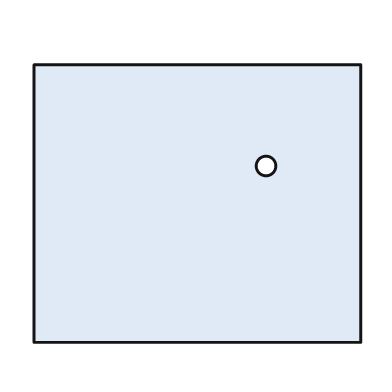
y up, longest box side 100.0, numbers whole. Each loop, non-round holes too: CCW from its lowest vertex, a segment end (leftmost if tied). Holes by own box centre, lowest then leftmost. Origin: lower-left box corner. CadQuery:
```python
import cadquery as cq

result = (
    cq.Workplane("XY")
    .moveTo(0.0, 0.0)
    .lineTo(100.0, 0.0)
    .lineTo(100.0, 85.0)
    .lineTo(0.0, 85.0)
    .close()
    .moveTo(71.0, 54.0)
    .circle(3.0)
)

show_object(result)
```